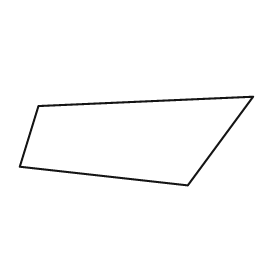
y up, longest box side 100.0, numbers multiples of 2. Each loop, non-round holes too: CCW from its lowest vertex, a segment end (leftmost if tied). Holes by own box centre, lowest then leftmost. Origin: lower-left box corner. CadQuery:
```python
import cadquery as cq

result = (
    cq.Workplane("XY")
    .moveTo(72.0, 0.0)
    .lineTo(100.0, 38.0)
    .lineTo(8.0, 34.0)
    .lineTo(0.0, 8.0)
    .close()
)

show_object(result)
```